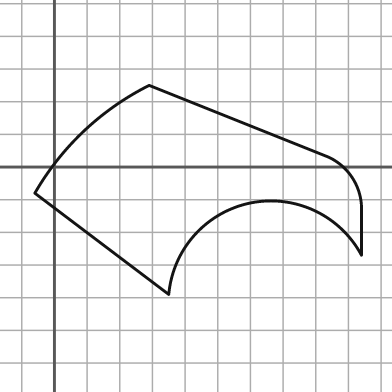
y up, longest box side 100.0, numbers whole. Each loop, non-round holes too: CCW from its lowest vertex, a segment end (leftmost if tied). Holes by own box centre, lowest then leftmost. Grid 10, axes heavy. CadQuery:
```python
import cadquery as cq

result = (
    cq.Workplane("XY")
    .moveTo(35.0, -39.0)
    .threePointArc((60.0, -11.0), (94.0, -27.0))
    .lineTo(94.0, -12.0)
    .threePointArc((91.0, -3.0), (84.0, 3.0))
    .lineTo(29.0, 25.0)
    .threePointArc((9.0, 11.0), (-6.0, -8.0))
    .close()
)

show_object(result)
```